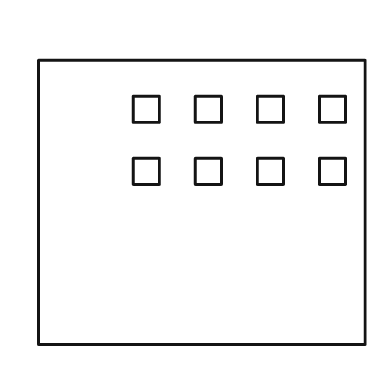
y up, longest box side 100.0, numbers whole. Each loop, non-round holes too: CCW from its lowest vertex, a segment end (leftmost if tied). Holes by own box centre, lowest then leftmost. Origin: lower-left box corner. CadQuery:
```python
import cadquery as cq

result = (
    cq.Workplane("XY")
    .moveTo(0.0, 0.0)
    .lineTo(100.0, 0.0)
    .lineTo(100.0, 87.0)
    .lineTo(0.0, 87.0)
    .close()
    .moveTo(29.0, 49.0)
    .lineTo(37.0, 49.0)
    .lineTo(37.0, 57.0)
    .lineTo(29.0, 57.0)
    .close()
    .moveTo(48.0, 49.0)
    .lineTo(56.0, 49.0)
    .lineTo(56.0, 57.0)
    .lineTo(48.0, 57.0)
    .close()
    .moveTo(67.0, 49.0)
    .lineTo(75.0, 49.0)
    .lineTo(75.0, 57.0)
    .lineTo(67.0, 57.0)
    .close()
    .moveTo(86.0, 49.0)
    .lineTo(94.0, 49.0)
    .lineTo(94.0, 57.0)
    .lineTo(86.0, 57.0)
    .close()
    .moveTo(29.0, 68.0)
    .lineTo(37.0, 68.0)
    .lineTo(37.0, 76.0)
    .lineTo(29.0, 76.0)
    .close()
    .moveTo(48.0, 68.0)
    .lineTo(56.0, 68.0)
    .lineTo(56.0, 76.0)
    .lineTo(48.0, 76.0)
    .close()
    .moveTo(67.0, 68.0)
    .lineTo(75.0, 68.0)
    .lineTo(75.0, 76.0)
    .lineTo(67.0, 76.0)
    .close()
    .moveTo(86.0, 68.0)
    .lineTo(94.0, 68.0)
    .lineTo(94.0, 76.0)
    .lineTo(86.0, 76.0)
    .close()
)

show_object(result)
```